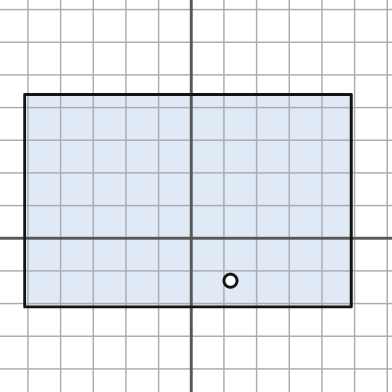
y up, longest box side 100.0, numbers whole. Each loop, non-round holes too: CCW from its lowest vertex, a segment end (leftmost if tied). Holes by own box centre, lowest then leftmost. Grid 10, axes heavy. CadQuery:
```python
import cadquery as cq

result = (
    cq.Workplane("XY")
    .moveTo(-51.0, -21.0)
    .lineTo(49.0, -21.0)
    .lineTo(49.0, 44.0)
    .lineTo(-51.0, 44.0)
    .close()
    .moveTo(12.0, -13.0)
    .circle(2.0)
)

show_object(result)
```